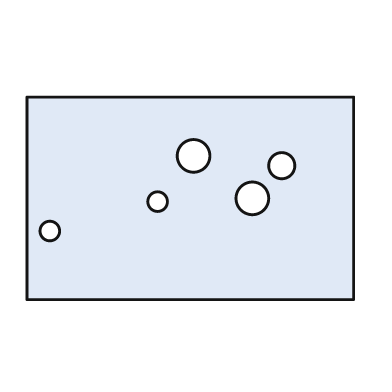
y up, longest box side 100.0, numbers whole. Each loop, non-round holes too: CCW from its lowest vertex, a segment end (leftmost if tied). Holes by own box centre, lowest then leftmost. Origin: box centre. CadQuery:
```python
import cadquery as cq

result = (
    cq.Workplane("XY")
    .moveTo(-50.0, -31.0)
    .lineTo(50.0, -31.0)
    .lineTo(50.0, 31.0)
    .lineTo(-50.0, 31.0)
    .close()
    .moveTo(-43.0, -10.0)
    .circle(3.0)
    .moveTo(-10.0, -1.0)
    .circle(3.0)
    .moveTo(19.0, 0.0)
    .circle(5.0)
    .moveTo(28.0, 10.0)
    .circle(4.0)
    .moveTo(1.0, 13.0)
    .circle(5.0)
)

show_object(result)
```